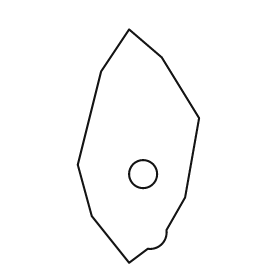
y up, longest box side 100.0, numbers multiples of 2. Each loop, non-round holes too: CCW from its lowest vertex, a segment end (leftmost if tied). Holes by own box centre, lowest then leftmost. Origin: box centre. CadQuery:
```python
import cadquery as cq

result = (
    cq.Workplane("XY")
    .moveTo(-4.0, -50.0)
    .lineTo(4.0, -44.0)
    .threePointArc((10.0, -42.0), (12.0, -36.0))
    .lineTo(20.0, -22.0)
    .lineTo(26.0, 12.0)
    .lineTo(10.0, 38.0)
    .lineTo(-4.0, 50.0)
    .lineTo(-16.0, 32.0)
    .lineTo(-26.0, -8.0)
    .lineTo(-20.0, -30.0)
    .close()
    .moveTo(2.0, -12.0)
    .circle(6.0)
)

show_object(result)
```